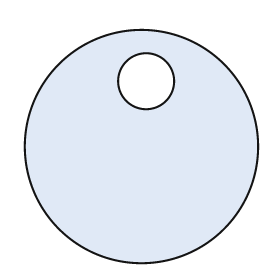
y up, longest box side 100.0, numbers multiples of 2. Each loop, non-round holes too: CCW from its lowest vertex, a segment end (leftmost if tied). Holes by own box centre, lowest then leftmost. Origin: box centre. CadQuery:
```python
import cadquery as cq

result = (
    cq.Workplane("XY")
    .moveTo(0.0, 0.0)
    .circle(50.0)
    .moveTo(2.0, 28.0)
    .circle(12.0)
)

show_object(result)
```